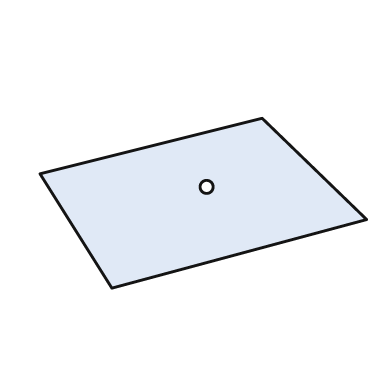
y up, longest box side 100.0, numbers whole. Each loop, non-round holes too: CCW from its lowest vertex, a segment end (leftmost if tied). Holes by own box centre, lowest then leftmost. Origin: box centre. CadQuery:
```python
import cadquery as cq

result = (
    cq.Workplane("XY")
    .moveTo(-28.0, -26.0)
    .lineTo(50.0, -5.0)
    .lineTo(18.0, 26.0)
    .lineTo(-50.0, 9.0)
    .close()
    .moveTo(1.0, 5.0)
    .circle(2.0)
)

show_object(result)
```